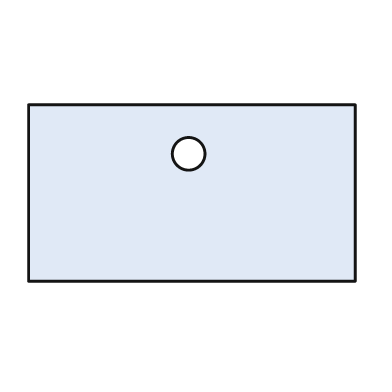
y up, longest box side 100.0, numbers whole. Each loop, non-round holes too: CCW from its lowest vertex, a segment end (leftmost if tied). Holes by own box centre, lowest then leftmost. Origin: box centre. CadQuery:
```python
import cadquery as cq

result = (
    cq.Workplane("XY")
    .moveTo(-50.0, -27.0)
    .lineTo(50.0, -27.0)
    .lineTo(50.0, 27.0)
    .lineTo(-50.0, 27.0)
    .close()
    .moveTo(-1.0, 12.0)
    .circle(5.0)
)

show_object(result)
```